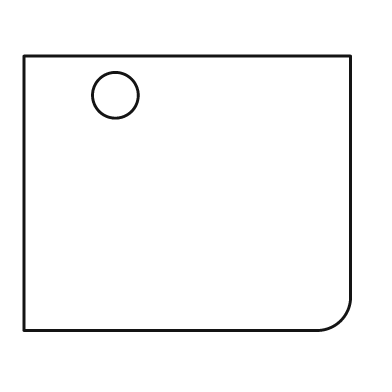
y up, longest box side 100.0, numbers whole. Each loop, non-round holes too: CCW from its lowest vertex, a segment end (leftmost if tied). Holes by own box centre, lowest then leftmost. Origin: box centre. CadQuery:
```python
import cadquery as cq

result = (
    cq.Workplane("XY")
    .moveTo(-50.0, -42.0)
    .lineTo(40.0, -42.0)
    .threePointArc((47.0, -39.0), (50.0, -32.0))
    .lineTo(50.0, 42.0)
    .lineTo(-50.0, 42.0)
    .close()
    .moveTo(-22.0, 30.0)
    .circle(7.0)
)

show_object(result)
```